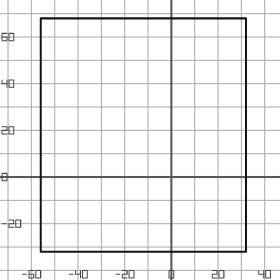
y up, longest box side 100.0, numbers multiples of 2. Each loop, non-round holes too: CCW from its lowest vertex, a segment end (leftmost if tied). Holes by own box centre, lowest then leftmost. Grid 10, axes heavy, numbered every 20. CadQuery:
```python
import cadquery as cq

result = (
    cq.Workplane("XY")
    .moveTo(-56.0, -32.0)
    .lineTo(32.0, -32.0)
    .lineTo(32.0, 68.0)
    .lineTo(-56.0, 68.0)
    .close()
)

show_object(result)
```